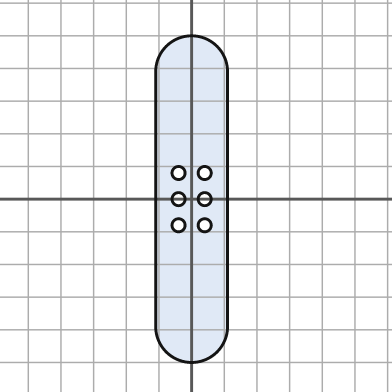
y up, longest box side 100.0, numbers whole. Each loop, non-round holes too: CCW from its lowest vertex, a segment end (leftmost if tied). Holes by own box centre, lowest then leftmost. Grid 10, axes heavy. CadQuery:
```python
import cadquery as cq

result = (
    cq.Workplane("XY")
    .moveTo(-11.0, -39.0)
    .threePointArc((0.0, -50.0), (11.0, -39.0))
    .lineTo(11.0, 39.0)
    .threePointArc((0.0, 50.0), (-11.0, 39.0))
    .close()
    .moveTo(-4.0, -8.0)
    .circle(2.0)
    .moveTo(4.0, -8.0)
    .circle(2.0)
    .moveTo(-4.0, 0.0)
    .circle(2.0)
    .moveTo(4.0, 0.0)
    .circle(2.0)
    .moveTo(-4.0, 8.0)
    .circle(2.0)
    .moveTo(4.0, 8.0)
    .circle(2.0)
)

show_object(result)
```